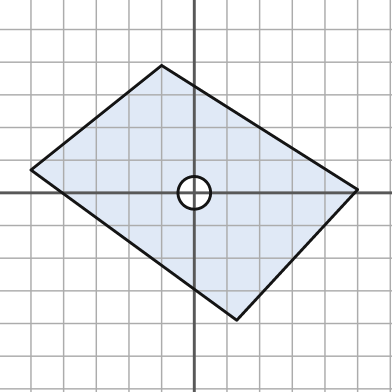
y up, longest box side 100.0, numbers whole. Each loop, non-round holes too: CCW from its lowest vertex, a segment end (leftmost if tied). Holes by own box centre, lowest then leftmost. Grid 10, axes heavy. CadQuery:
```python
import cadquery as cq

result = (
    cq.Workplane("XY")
    .moveTo(13.0, -39.0)
    .lineTo(50.0, 1.0)
    .lineTo(-10.0, 39.0)
    .lineTo(-50.0, 7.0)
    .close()
    .moveTo(0.0, 0.0)
    .circle(5.0)
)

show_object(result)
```